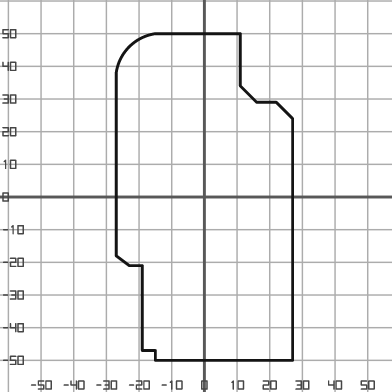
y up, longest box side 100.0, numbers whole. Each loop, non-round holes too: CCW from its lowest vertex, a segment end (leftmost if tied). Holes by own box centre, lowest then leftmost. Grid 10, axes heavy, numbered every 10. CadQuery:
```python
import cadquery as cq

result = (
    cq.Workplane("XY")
    .moveTo(-15.0, -50.0)
    .lineTo(27.0, -50.0)
    .lineTo(27.0, 24.0)
    .lineTo(22.0, 29.0)
    .lineTo(16.0, 29.0)
    .lineTo(11.0, 34.0)
    .lineTo(11.0, 50.0)
    .lineTo(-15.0, 50.0)
    .threePointArc((-23.0, 46.0), (-27.0, 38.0))
    .lineTo(-27.0, -18.0)
    .lineTo(-23.0, -21.0)
    .lineTo(-19.0, -21.0)
    .lineTo(-19.0, -47.0)
    .lineTo(-15.0, -47.0)
    .close()
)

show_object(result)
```